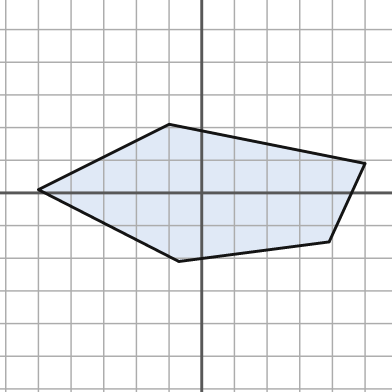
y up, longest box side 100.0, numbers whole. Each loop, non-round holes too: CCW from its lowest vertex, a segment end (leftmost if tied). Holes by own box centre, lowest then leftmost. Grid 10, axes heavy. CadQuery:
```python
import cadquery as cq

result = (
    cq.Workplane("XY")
    .moveTo(-7.0, -21.0)
    .lineTo(39.0, -15.0)
    .lineTo(50.0, 9.0)
    .lineTo(-10.0, 21.0)
    .lineTo(-50.0, 1.0)
    .close()
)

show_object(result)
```